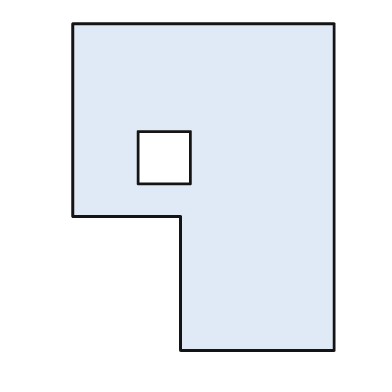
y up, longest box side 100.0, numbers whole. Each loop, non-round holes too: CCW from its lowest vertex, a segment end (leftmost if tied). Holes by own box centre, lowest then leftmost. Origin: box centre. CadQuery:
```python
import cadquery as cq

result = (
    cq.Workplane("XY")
    .moveTo(-7.0, -50.0)
    .lineTo(40.0, -50.0)
    .lineTo(40.0, 50.0)
    .lineTo(-40.0, 50.0)
    .lineTo(-40.0, -9.0)
    .lineTo(-7.0, -9.0)
    .close()
    .moveTo(-20.0, 1.0)
    .lineTo(-4.0, 1.0)
    .lineTo(-4.0, 17.0)
    .lineTo(-20.0, 17.0)
    .close()
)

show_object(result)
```